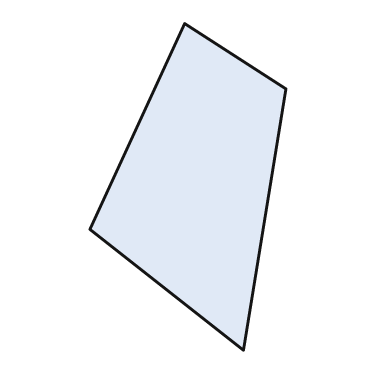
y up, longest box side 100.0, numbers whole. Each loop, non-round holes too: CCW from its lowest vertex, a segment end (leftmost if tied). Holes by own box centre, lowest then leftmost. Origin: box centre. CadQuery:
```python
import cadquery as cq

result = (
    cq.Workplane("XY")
    .moveTo(17.0, -50.0)
    .lineTo(30.0, 30.0)
    .lineTo(-1.0, 50.0)
    .lineTo(-30.0, -13.0)
    .close()
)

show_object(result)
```